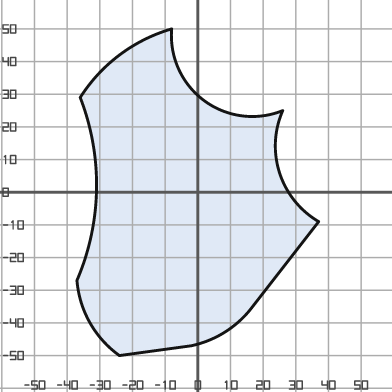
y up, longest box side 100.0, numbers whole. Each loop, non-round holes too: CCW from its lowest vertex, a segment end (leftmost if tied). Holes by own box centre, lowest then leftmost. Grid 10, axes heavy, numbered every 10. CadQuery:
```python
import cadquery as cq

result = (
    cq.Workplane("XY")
    .moveTo(-24.0, -50.0)
    .lineTo(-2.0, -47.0)
    .threePointArc((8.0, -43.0), (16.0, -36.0))
    .lineTo(37.0, -9.0)
    .threePointArc((25.0, 6.0), (26.0, 25.0))
    .threePointArc((2.0, 28.0), (-8.0, 50.0))
    .threePointArc((-24.0, 42.0), (-36.0, 29.0))
    .threePointArc((-31.0, 1.0), (-37.0, -27.0))
    .threePointArc((-33.0, -40.0), (-24.0, -50.0))
    .close()
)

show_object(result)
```